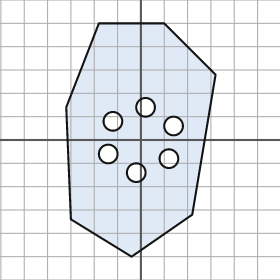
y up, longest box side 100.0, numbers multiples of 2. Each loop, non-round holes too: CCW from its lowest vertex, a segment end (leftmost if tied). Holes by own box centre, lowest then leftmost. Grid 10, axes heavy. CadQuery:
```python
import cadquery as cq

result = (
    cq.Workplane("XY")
    .moveTo(-4.0, -50.0)
    .lineTo(22.0, -32.0)
    .lineTo(32.0, 28.0)
    .lineTo(10.0, 50.0)
    .lineTo(-18.0, 50.0)
    .lineTo(-32.0, 14.0)
    .lineTo(-30.0, -34.0)
    .close()
    .moveTo(-2.0, -14.0)
    .circle(4.0)
    .moveTo(12.0, -8.0)
    .circle(4.0)
    .moveTo(-14.0, -6.0)
    .circle(4.0)
    .moveTo(14.0, 6.0)
    .circle(4.0)
    .moveTo(-12.0, 8.0)
    .circle(4.0)
    .moveTo(2.0, 14.0)
    .circle(4.0)
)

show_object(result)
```